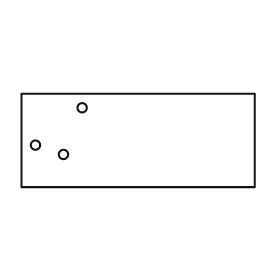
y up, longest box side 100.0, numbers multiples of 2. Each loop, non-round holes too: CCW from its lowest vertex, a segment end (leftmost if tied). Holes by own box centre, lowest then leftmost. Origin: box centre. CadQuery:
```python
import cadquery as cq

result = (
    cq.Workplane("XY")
    .moveTo(-50.0, -20.0)
    .lineTo(50.0, -20.0)
    .lineTo(50.0, 20.0)
    .lineTo(-50.0, 20.0)
    .close()
    .moveTo(-32.0, -6.0)
    .circle(2.0)
    .moveTo(-44.0, -2.0)
    .circle(2.0)
    .moveTo(-24.0, 14.0)
    .circle(2.0)
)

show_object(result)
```